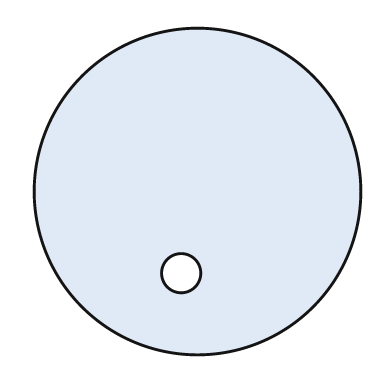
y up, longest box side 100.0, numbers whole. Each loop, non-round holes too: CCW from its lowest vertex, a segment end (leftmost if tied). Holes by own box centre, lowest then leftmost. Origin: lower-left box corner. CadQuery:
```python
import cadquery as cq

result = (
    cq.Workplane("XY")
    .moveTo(50.0, 50.0)
    .circle(50.0)
    .moveTo(45.0, 25.0)
    .circle(6.0)
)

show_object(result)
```